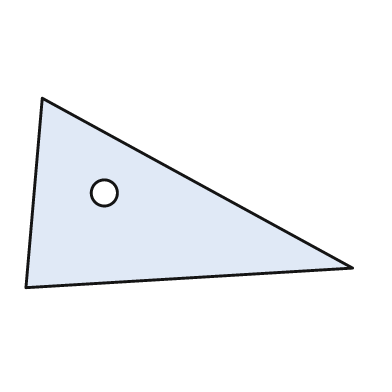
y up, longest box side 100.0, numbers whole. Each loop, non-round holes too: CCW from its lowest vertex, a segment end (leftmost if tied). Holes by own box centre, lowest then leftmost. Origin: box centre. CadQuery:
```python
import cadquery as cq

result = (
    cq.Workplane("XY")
    .moveTo(-50.0, -29.0)
    .lineTo(50.0, -23.0)
    .lineTo(-45.0, 29.0)
    .close()
    .moveTo(-26.0, 0.0)
    .circle(4.0)
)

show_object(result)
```